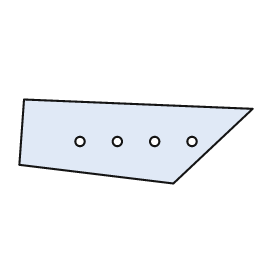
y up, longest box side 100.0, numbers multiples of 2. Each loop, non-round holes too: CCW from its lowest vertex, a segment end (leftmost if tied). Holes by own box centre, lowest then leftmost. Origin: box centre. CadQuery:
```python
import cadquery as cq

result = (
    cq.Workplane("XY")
    .moveTo(16.0, -18.0)
    .lineTo(50.0, 14.0)
    .lineTo(-48.0, 18.0)
    .lineTo(-50.0, -10.0)
    .close()
    .moveTo(-24.0, 0.0)
    .circle(2.0)
    .moveTo(-8.0, 0.0)
    .circle(2.0)
    .moveTo(8.0, 0.0)
    .circle(2.0)
    .moveTo(24.0, 0.0)
    .circle(2.0)
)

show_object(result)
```